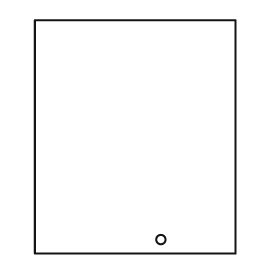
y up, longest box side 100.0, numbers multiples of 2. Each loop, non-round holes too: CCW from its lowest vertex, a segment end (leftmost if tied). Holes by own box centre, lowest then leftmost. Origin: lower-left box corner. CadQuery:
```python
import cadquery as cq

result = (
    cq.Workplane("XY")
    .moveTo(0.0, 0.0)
    .lineTo(86.0, 0.0)
    .lineTo(86.0, 100.0)
    .lineTo(0.0, 100.0)
    .close()
    .moveTo(54.0, 6.0)
    .circle(2.0)
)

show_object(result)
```